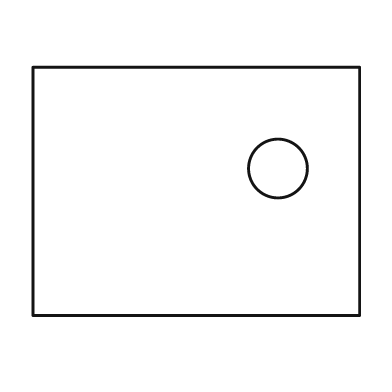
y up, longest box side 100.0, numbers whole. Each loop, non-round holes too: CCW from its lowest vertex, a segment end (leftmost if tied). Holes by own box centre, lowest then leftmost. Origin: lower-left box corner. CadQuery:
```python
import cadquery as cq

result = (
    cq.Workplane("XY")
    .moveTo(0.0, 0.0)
    .lineTo(100.0, 0.0)
    .lineTo(100.0, 76.0)
    .lineTo(0.0, 76.0)
    .close()
    .moveTo(75.0, 45.0)
    .circle(9.0)
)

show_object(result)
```